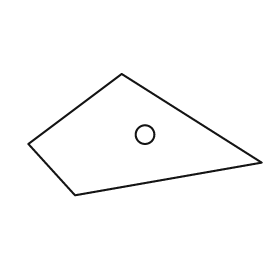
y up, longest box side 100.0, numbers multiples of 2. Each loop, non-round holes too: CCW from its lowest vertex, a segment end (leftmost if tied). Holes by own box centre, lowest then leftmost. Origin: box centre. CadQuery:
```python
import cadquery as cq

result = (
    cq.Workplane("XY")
    .moveTo(-30.0, -26.0)
    .lineTo(50.0, -12.0)
    .lineTo(-10.0, 26.0)
    .lineTo(-50.0, -4.0)
    .close()
    .moveTo(0.0, 0.0)
    .circle(4.0)
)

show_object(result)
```